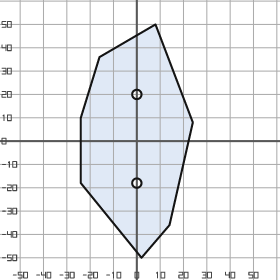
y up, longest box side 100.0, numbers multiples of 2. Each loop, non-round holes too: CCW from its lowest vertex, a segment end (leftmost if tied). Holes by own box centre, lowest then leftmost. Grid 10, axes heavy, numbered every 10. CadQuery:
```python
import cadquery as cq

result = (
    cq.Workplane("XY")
    .moveTo(2.0, -50.0)
    .lineTo(14.0, -36.0)
    .lineTo(24.0, 8.0)
    .lineTo(8.0, 50.0)
    .lineTo(-16.0, 36.0)
    .lineTo(-24.0, 10.0)
    .lineTo(-24.0, -18.0)
    .close()
    .moveTo(0.0, -18.0)
    .circle(2.0)
    .moveTo(0.0, 20.0)
    .circle(2.0)
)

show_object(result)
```